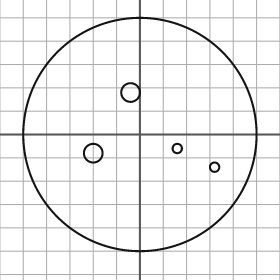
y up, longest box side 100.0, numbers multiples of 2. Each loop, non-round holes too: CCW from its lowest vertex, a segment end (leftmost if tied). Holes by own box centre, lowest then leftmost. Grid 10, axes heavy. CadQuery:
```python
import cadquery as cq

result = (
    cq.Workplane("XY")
    .moveTo(0.0, 0.0)
    .circle(50.0)
    .moveTo(32.0, -14.0)
    .circle(2.0)
    .moveTo(-20.0, -8.0)
    .circle(4.0)
    .moveTo(16.0, -6.0)
    .circle(2.0)
    .moveTo(-4.0, 18.0)
    .circle(4.0)
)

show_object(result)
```